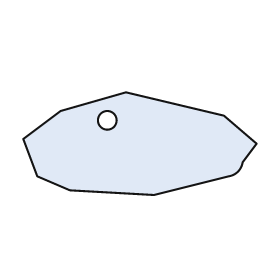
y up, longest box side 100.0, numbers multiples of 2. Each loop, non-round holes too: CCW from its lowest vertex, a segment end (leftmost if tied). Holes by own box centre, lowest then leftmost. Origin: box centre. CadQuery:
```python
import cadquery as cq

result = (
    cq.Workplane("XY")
    .moveTo(6.0, -22.0)
    .lineTo(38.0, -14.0)
    .threePointArc((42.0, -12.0), (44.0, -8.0))
    .lineTo(50.0, 0.0)
    .lineTo(36.0, 12.0)
    .lineTo(-6.0, 22.0)
    .lineTo(-34.0, 14.0)
    .lineTo(-50.0, 2.0)
    .lineTo(-44.0, -14.0)
    .lineTo(-30.0, -20.0)
    .close()
    .moveTo(-14.0, 10.0)
    .circle(4.0)
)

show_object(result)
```